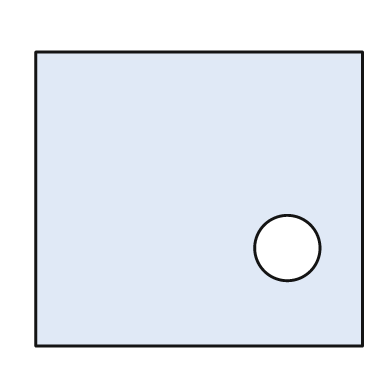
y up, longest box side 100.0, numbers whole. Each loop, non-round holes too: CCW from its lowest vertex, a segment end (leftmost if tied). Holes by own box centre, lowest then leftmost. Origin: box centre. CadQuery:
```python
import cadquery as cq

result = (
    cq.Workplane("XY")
    .moveTo(-50.0, -45.0)
    .lineTo(50.0, -45.0)
    .lineTo(50.0, 45.0)
    .lineTo(-50.0, 45.0)
    .close()
    .moveTo(27.0, -15.0)
    .circle(10.0)
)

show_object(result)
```